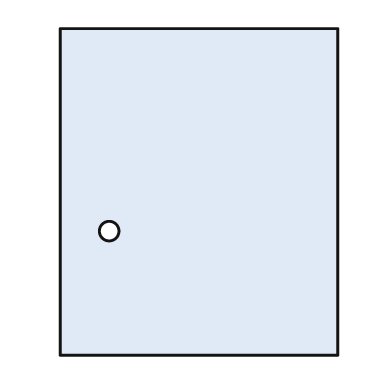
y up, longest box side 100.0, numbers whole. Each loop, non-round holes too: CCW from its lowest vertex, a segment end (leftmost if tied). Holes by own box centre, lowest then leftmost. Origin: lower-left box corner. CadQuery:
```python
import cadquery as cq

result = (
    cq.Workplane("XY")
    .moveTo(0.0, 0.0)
    .lineTo(85.0, 0.0)
    .lineTo(85.0, 100.0)
    .lineTo(0.0, 100.0)
    .close()
    .moveTo(15.0, 38.0)
    .circle(3.0)
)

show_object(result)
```